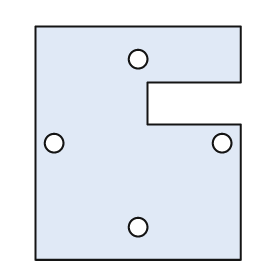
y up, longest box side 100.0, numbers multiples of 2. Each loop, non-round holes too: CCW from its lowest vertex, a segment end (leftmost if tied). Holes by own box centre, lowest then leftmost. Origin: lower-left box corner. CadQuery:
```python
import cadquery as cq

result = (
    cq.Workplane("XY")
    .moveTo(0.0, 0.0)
    .lineTo(88.0, 0.0)
    .lineTo(88.0, 58.0)
    .lineTo(48.0, 58.0)
    .lineTo(48.0, 76.0)
    .lineTo(88.0, 76.0)
    .lineTo(88.0, 100.0)
    .lineTo(0.0, 100.0)
    .close()
    .moveTo(44.0, 14.0)
    .circle(4.0)
    .moveTo(8.0, 50.0)
    .circle(4.0)
    .moveTo(80.0, 50.0)
    .circle(4.0)
    .moveTo(44.0, 86.0)
    .circle(4.0)
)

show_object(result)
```